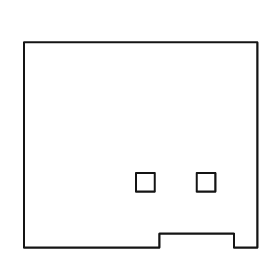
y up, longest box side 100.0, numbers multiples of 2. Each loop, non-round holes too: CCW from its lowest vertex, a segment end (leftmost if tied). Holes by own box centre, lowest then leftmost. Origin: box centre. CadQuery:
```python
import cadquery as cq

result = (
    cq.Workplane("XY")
    .moveTo(-50.0, -44.0)
    .lineTo(8.0, -44.0)
    .lineTo(8.0, -38.0)
    .lineTo(40.0, -38.0)
    .lineTo(40.0, -44.0)
    .lineTo(50.0, -44.0)
    .lineTo(50.0, 44.0)
    .lineTo(-50.0, 44.0)
    .close()
    .moveTo(-2.0, -20.0)
    .lineTo(6.0, -20.0)
    .lineTo(6.0, -12.0)
    .lineTo(-2.0, -12.0)
    .close()
    .moveTo(24.0, -20.0)
    .lineTo(32.0, -20.0)
    .lineTo(32.0, -12.0)
    .lineTo(24.0, -12.0)
    .close()
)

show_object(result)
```